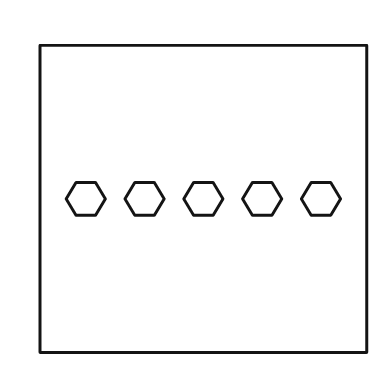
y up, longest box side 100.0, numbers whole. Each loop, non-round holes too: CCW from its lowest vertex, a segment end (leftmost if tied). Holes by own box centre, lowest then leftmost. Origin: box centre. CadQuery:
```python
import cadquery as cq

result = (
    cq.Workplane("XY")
    .moveTo(-50.0, -47.0)
    .lineTo(50.0, -47.0)
    .lineTo(50.0, 47.0)
    .lineTo(-50.0, 47.0)
    .close()
    .moveTo(-39.0, -5.0)
    .lineTo(-33.0, -5.0)
    .lineTo(-30.0, 0.0)
    .lineTo(-33.0, 5.0)
    .lineTo(-39.0, 5.0)
    .lineTo(-42.0, 0.0)
    .close()
    .moveTo(-21.0, -5.0)
    .lineTo(-15.0, -5.0)
    .lineTo(-12.0, 0.0)
    .lineTo(-15.0, 5.0)
    .lineTo(-21.0, 5.0)
    .lineTo(-24.0, 0.0)
    .close()
    .moveTo(-3.0, -5.0)
    .lineTo(3.0, -5.0)
    .lineTo(6.0, 0.0)
    .lineTo(3.0, 5.0)
    .lineTo(-3.0, 5.0)
    .lineTo(-6.0, 0.0)
    .close()
    .moveTo(15.0, -5.0)
    .lineTo(21.0, -5.0)
    .lineTo(24.0, 0.0)
    .lineTo(21.0, 5.0)
    .lineTo(15.0, 5.0)
    .lineTo(12.0, 0.0)
    .close()
    .moveTo(33.0, -5.0)
    .lineTo(39.0, -5.0)
    .lineTo(42.0, 0.0)
    .lineTo(39.0, 5.0)
    .lineTo(33.0, 5.0)
    .lineTo(30.0, 0.0)
    .close()
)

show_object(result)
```